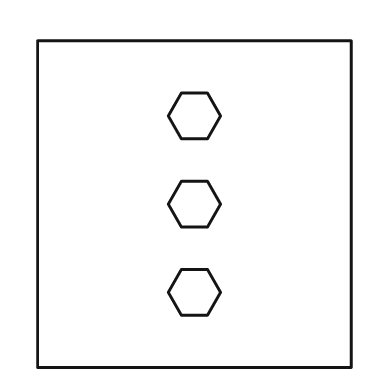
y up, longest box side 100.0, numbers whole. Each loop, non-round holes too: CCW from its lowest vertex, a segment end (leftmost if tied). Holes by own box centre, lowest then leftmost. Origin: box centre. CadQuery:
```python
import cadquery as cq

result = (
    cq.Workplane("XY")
    .moveTo(-48.0, -50.0)
    .lineTo(48.0, -50.0)
    .lineTo(48.0, 50.0)
    .lineTo(-48.0, 50.0)
    .close()
    .moveTo(-4.0, -34.0)
    .lineTo(4.0, -34.0)
    .lineTo(8.0, -27.0)
    .lineTo(4.0, -20.0)
    .lineTo(-4.0, -20.0)
    .lineTo(-8.0, -27.0)
    .close()
    .moveTo(-4.0, -7.0)
    .lineTo(4.0, -7.0)
    .lineTo(8.0, 0.0)
    .lineTo(4.0, 7.0)
    .lineTo(-4.0, 7.0)
    .lineTo(-8.0, 0.0)
    .close()
    .moveTo(-4.0, 20.0)
    .lineTo(4.0, 20.0)
    .lineTo(8.0, 27.0)
    .lineTo(4.0, 34.0)
    .lineTo(-4.0, 34.0)
    .lineTo(-8.0, 27.0)
    .close()
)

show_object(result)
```